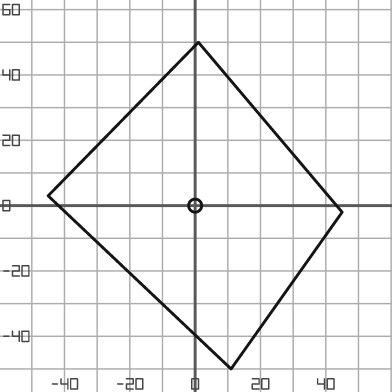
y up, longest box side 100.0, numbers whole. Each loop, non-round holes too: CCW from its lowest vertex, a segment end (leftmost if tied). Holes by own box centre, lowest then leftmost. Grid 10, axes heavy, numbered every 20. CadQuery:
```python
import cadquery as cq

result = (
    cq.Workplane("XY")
    .moveTo(11.0, -50.0)
    .lineTo(45.0, -2.0)
    .lineTo(1.0, 50.0)
    .lineTo(-45.0, 3.0)
    .close()
    .moveTo(0.0, 0.0)
    .circle(2.0)
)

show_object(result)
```